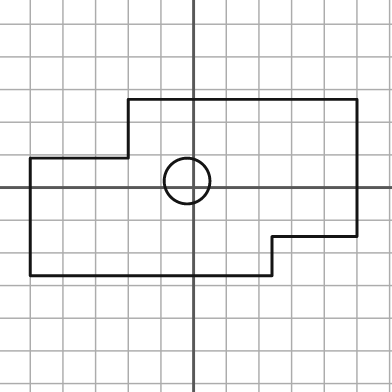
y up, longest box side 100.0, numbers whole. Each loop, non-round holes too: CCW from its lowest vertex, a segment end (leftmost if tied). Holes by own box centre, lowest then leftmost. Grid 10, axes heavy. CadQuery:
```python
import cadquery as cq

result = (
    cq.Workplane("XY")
    .moveTo(-50.0, -27.0)
    .lineTo(24.0, -27.0)
    .lineTo(24.0, -15.0)
    .lineTo(50.0, -15.0)
    .lineTo(50.0, 27.0)
    .lineTo(-20.0, 27.0)
    .lineTo(-20.0, 9.0)
    .lineTo(-50.0, 9.0)
    .close()
    .moveTo(-2.0, 2.0)
    .circle(7.0)
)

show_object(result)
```